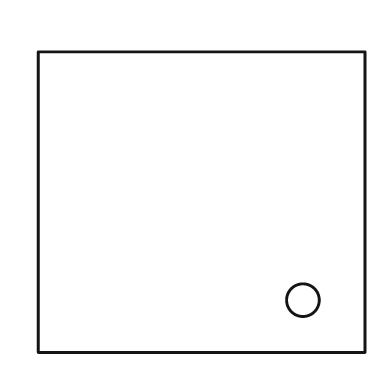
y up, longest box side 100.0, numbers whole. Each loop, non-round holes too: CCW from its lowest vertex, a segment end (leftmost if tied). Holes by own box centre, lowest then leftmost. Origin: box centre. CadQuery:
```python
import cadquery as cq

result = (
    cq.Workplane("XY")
    .moveTo(-50.0, -46.0)
    .lineTo(50.0, -46.0)
    .lineTo(50.0, 46.0)
    .lineTo(-50.0, 46.0)
    .close()
    .moveTo(31.0, -30.0)
    .circle(5.0)
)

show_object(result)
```